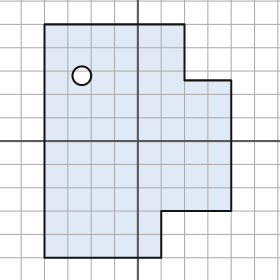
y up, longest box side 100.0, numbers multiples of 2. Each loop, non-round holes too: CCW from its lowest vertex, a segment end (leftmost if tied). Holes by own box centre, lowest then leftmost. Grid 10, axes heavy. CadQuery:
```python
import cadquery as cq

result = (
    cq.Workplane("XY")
    .moveTo(-40.0, -50.0)
    .lineTo(10.0, -50.0)
    .lineTo(10.0, -30.0)
    .lineTo(40.0, -30.0)
    .lineTo(40.0, 26.0)
    .lineTo(20.0, 26.0)
    .lineTo(20.0, 50.0)
    .lineTo(-40.0, 50.0)
    .close()
    .moveTo(-24.0, 28.0)
    .circle(4.0)
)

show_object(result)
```